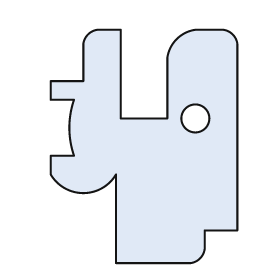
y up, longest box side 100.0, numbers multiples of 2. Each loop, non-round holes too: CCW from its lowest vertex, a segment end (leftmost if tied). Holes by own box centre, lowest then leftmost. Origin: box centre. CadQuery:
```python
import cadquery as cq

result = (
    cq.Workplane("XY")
    .moveTo(-12.0, -50.0)
    .lineTo(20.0, -50.0)
    .threePointArc((24.0, -48.0), (26.0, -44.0))
    .lineTo(26.0, -36.0)
    .lineTo(40.0, -36.0)
    .lineTo(40.0, 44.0)
    .threePointArc((38.0, 48.0), (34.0, 50.0))
    .lineTo(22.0, 50.0)
    .threePointArc((14.0, 46.0), (10.0, 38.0))
    .lineTo(10.0, 12.0)
    .lineTo(-10.0, 12.0)
    .lineTo(-10.0, 50.0)
    .lineTo(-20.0, 50.0)
    .threePointArc((-24.0, 48.0), (-26.0, 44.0))
    .lineTo(-26.0, 28.0)
    .lineTo(-40.0, 28.0)
    .lineTo(-40.0, 20.0)
    .lineTo(-30.0, 20.0)
    .threePointArc((-32.0, 8.0), (-30.0, -4.0))
    .lineTo(-40.0, -4.0)
    .lineTo(-40.0, -12.0)
    .threePointArc((-26.0, -20.0), (-12.0, -12.0))
    .close()
    .moveTo(22.0, 12.0)
    .circle(6.0)
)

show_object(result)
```